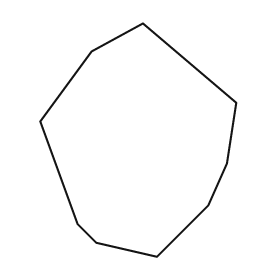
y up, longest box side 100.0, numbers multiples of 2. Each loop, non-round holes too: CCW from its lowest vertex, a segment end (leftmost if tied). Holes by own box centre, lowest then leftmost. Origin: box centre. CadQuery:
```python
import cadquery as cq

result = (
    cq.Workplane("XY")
    .moveTo(8.0, -50.0)
    .lineTo(30.0, -28.0)
    .lineTo(38.0, -10.0)
    .lineTo(42.0, 16.0)
    .lineTo(2.0, 50.0)
    .lineTo(-20.0, 38.0)
    .lineTo(-42.0, 8.0)
    .lineTo(-26.0, -36.0)
    .lineTo(-18.0, -44.0)
    .close()
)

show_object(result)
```